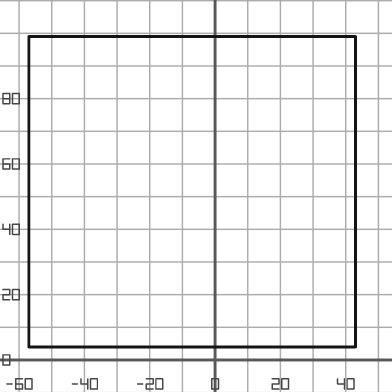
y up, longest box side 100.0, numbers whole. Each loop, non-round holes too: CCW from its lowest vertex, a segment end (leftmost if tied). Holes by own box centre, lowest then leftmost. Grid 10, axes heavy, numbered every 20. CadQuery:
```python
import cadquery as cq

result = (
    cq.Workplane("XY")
    .moveTo(-57.0, 4.0)
    .lineTo(43.0, 4.0)
    .lineTo(43.0, 99.0)
    .lineTo(-57.0, 99.0)
    .close()
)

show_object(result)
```